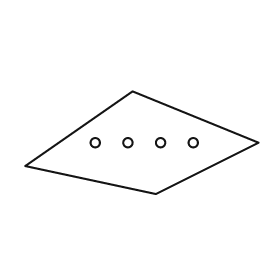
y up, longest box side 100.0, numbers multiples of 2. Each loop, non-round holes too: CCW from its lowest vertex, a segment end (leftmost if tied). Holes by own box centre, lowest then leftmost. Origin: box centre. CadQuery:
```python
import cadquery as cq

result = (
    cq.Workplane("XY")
    .moveTo(6.0, -22.0)
    .lineTo(50.0, 0.0)
    .lineTo(-4.0, 22.0)
    .lineTo(-50.0, -10.0)
    .close()
    .moveTo(-20.0, 0.0)
    .circle(2.0)
    .moveTo(-6.0, 0.0)
    .circle(2.0)
    .moveTo(8.0, 0.0)
    .circle(2.0)
    .moveTo(22.0, 0.0)
    .circle(2.0)
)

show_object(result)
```